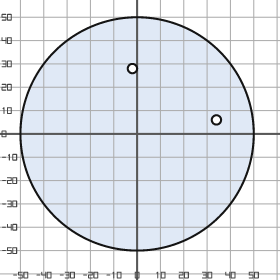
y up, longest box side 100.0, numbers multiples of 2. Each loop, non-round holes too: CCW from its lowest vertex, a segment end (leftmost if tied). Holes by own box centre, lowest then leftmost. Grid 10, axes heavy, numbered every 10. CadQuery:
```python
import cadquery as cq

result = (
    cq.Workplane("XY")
    .moveTo(0.0, 0.0)
    .circle(50.0)
    .moveTo(34.0, 6.0)
    .circle(2.0)
    .moveTo(-2.0, 28.0)
    .circle(2.0)
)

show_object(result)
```